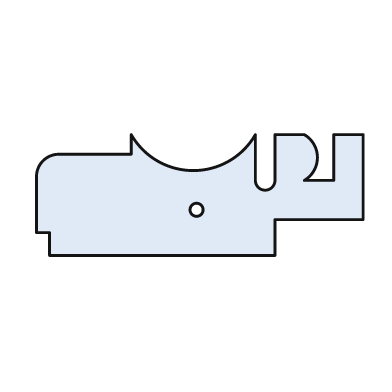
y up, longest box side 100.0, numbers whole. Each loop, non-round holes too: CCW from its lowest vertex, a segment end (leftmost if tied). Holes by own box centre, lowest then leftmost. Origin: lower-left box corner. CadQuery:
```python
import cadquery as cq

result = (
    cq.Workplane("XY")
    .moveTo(4.0, 0.0)
    .lineTo(73.0, 0.0)
    .lineTo(73.0, 11.0)
    .lineTo(100.0, 11.0)
    .lineTo(100.0, 37.0)
    .lineTo(91.0, 37.0)
    .lineTo(91.0, 23.0)
    .lineTo(82.0, 23.0)
    .threePointArc((86.0, 30.0), (82.0, 37.0))
    .lineTo(73.0, 37.0)
    .lineTo(73.0, 23.0)
    .threePointArc((70.0, 20.0), (67.0, 23.0))
    .lineTo(67.0, 37.0)
    .threePointArc((48.0, 26.0), (29.0, 37.0))
    .lineTo(29.0, 31.0)
    .lineTo(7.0, 31.0)
    .threePointArc((2.0, 29.0), (0.0, 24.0))
    .lineTo(0.0, 7.0)
    .lineTo(4.0, 7.0)
    .close()
    .moveTo(49.0, 14.0)
    .circle(2.0)
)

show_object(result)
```